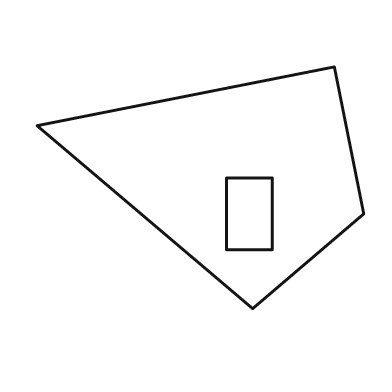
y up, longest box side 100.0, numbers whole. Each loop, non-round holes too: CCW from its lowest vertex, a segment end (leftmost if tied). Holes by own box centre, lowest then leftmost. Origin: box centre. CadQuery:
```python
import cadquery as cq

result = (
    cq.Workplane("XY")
    .moveTo(16.0, -37.0)
    .lineTo(50.0, -8.0)
    .lineTo(41.0, 37.0)
    .lineTo(-50.0, 19.0)
    .close()
    .moveTo(8.0, -19.0)
    .lineTo(22.0, -19.0)
    .lineTo(22.0, 3.0)
    .lineTo(8.0, 3.0)
    .close()
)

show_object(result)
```